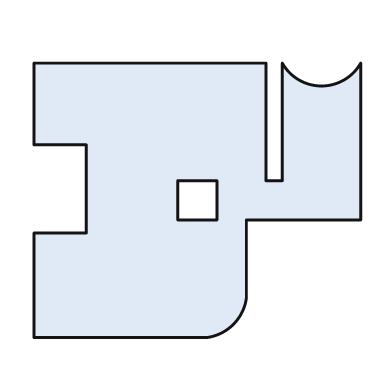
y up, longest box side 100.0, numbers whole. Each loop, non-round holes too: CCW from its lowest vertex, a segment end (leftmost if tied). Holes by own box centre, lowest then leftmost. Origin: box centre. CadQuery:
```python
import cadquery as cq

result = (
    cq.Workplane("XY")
    .moveTo(-50.0, -42.0)
    .lineTo(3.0, -42.0)
    .threePointArc((11.0, -38.0), (15.0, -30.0))
    .lineTo(15.0, -6.0)
    .lineTo(50.0, -6.0)
    .lineTo(50.0, 42.0)
    .threePointArc((38.0, 35.0), (26.0, 42.0))
    .lineTo(26.0, 6.0)
    .lineTo(21.0, 6.0)
    .lineTo(21.0, 42.0)
    .lineTo(-50.0, 42.0)
    .lineTo(-50.0, 17.0)
    .lineTo(-34.0, 17.0)
    .lineTo(-34.0, -10.0)
    .lineTo(-50.0, -10.0)
    .close()
    .moveTo(-6.0, -6.0)
    .lineTo(6.0, -6.0)
    .lineTo(6.0, 6.0)
    .lineTo(-6.0, 6.0)
    .close()
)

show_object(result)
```